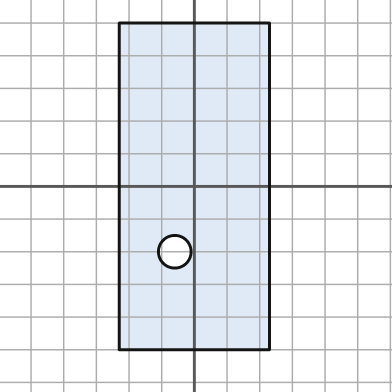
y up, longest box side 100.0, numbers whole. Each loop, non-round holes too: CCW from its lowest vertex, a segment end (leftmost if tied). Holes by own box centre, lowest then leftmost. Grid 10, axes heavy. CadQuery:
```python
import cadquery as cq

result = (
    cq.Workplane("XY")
    .moveTo(-23.0, -50.0)
    .lineTo(23.0, -50.0)
    .lineTo(23.0, 50.0)
    .lineTo(-23.0, 50.0)
    .close()
    .moveTo(-6.0, -20.0)
    .circle(5.0)
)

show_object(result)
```